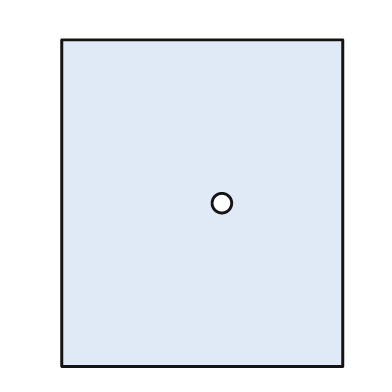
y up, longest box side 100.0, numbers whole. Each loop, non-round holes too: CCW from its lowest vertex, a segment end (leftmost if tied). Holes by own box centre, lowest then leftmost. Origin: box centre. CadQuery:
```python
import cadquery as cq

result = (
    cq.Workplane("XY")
    .moveTo(-43.0, -50.0)
    .lineTo(43.0, -50.0)
    .lineTo(43.0, 50.0)
    .lineTo(-43.0, 50.0)
    .close()
    .moveTo(6.0, 0.0)
    .circle(3.0)
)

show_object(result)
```